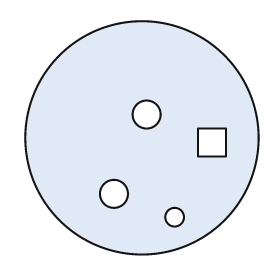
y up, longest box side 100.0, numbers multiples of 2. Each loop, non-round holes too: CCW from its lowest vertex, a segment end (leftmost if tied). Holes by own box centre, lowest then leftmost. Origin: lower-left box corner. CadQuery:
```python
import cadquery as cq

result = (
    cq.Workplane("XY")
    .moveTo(50.0, 50.0)
    .circle(50.0)
    .moveTo(64.0, 16.0)
    .circle(4.0)
    .moveTo(38.0, 26.0)
    .circle(6.0)
    .moveTo(74.0, 42.0)
    .lineTo(86.0, 42.0)
    .lineTo(86.0, 54.0)
    .lineTo(74.0, 54.0)
    .close()
    .moveTo(52.0, 60.0)
    .circle(6.0)
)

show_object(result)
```